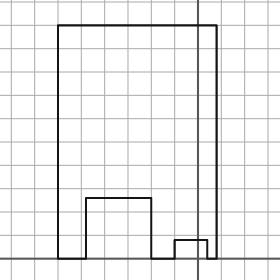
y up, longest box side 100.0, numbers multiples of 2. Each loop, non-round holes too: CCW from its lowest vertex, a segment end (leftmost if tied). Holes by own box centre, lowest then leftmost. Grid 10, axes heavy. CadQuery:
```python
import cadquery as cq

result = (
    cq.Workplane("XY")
    .moveTo(-60.0, 0.0)
    .lineTo(-48.0, 0.0)
    .lineTo(-48.0, 26.0)
    .lineTo(-20.0, 26.0)
    .lineTo(-20.0, 0.0)
    .lineTo(-10.0, 0.0)
    .lineTo(-10.0, 8.0)
    .lineTo(4.0, 8.0)
    .lineTo(4.0, 0.0)
    .lineTo(8.0, 0.0)
    .lineTo(8.0, 100.0)
    .lineTo(-60.0, 100.0)
    .close()
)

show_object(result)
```